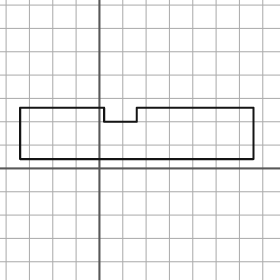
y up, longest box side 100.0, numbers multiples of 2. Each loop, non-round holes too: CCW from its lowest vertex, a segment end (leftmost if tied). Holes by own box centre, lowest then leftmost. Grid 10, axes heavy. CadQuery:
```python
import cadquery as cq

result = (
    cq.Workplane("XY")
    .moveTo(-34.0, 4.0)
    .lineTo(66.0, 4.0)
    .lineTo(66.0, 26.0)
    .lineTo(16.0, 26.0)
    .lineTo(16.0, 20.0)
    .lineTo(2.0, 20.0)
    .lineTo(2.0, 26.0)
    .lineTo(-34.0, 26.0)
    .close()
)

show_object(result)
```